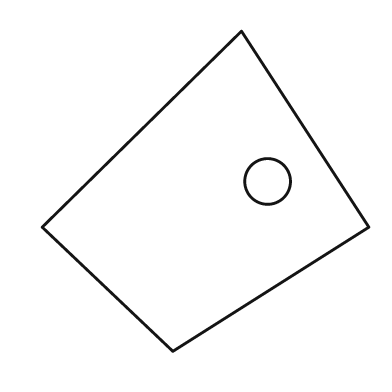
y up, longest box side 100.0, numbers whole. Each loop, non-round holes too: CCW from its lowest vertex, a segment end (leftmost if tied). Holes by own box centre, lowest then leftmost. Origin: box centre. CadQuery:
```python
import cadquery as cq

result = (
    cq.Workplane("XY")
    .moveTo(-10.0, -49.0)
    .lineTo(50.0, -11.0)
    .lineTo(11.0, 49.0)
    .lineTo(-50.0, -11.0)
    .close()
    .moveTo(19.0, 3.0)
    .circle(7.0)
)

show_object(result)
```